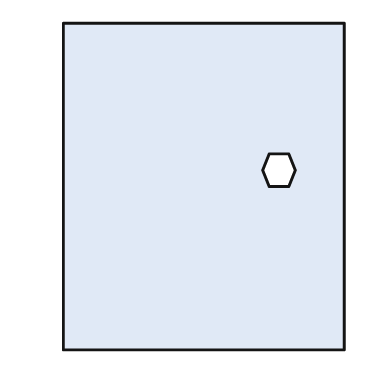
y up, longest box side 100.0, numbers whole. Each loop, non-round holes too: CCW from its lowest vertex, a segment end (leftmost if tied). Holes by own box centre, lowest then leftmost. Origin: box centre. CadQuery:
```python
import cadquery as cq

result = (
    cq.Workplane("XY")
    .moveTo(-43.0, -50.0)
    .lineTo(43.0, -50.0)
    .lineTo(43.0, 50.0)
    .lineTo(-43.0, 50.0)
    .close()
    .moveTo(20.0, 0.0)
    .lineTo(26.0, 0.0)
    .lineTo(28.0, 5.0)
    .lineTo(26.0, 10.0)
    .lineTo(20.0, 10.0)
    .lineTo(18.0, 5.0)
    .close()
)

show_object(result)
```